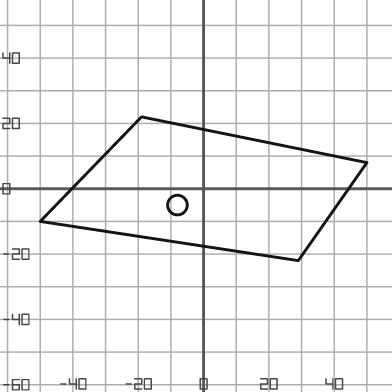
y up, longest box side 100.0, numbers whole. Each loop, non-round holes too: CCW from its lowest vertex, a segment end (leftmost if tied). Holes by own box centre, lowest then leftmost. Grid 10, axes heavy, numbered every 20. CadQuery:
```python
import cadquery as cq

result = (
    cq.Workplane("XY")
    .moveTo(29.0, -22.0)
    .lineTo(50.0, 8.0)
    .lineTo(-19.0, 22.0)
    .lineTo(-50.0, -10.0)
    .close()
    .moveTo(-8.0, -5.0)
    .circle(3.0)
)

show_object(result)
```